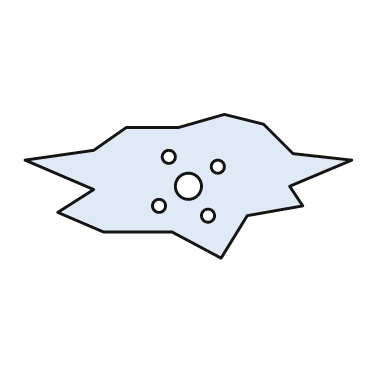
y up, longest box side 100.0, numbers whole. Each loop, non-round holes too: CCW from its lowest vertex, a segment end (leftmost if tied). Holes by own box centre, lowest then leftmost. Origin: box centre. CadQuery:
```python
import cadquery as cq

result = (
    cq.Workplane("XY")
    .moveTo(10.0, -22.0)
    .lineTo(18.0, -9.0)
    .lineTo(35.0, -6.0)
    .lineTo(31.0, 0.0)
    .lineTo(50.0, 8.0)
    .lineTo(32.0, 10.0)
    .lineTo(23.0, 19.0)
    .lineTo(11.0, 22.0)
    .lineTo(-3.0, 18.0)
    .lineTo(-19.0, 18.0)
    .lineTo(-29.0, 11.0)
    .lineTo(-50.0, 8.0)
    .lineTo(-29.0, -1.0)
    .lineTo(-40.0, -8.0)
    .lineTo(-26.0, -14.0)
    .lineTo(-5.0, -14.0)
    .close()
    .moveTo(6.0, -9.0)
    .circle(2.0)
    .moveTo(-9.0, -6.0)
    .circle(2.0)
    .moveTo(0.0, 0.0)
    .circle(4.0)
    .moveTo(9.0, 6.0)
    .circle(2.0)
    .moveTo(-6.0, 9.0)
    .circle(2.0)
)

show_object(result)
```